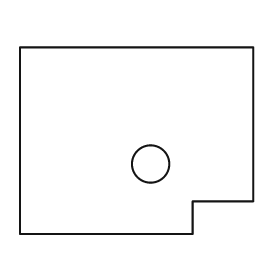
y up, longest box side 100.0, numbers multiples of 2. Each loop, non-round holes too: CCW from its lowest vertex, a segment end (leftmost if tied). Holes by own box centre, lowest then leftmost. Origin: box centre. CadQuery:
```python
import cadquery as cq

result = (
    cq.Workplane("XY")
    .moveTo(-50.0, -40.0)
    .lineTo(24.0, -40.0)
    .lineTo(24.0, -26.0)
    .lineTo(50.0, -26.0)
    .lineTo(50.0, 40.0)
    .lineTo(-50.0, 40.0)
    .close()
    .moveTo(6.0, -10.0)
    .circle(8.0)
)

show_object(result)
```